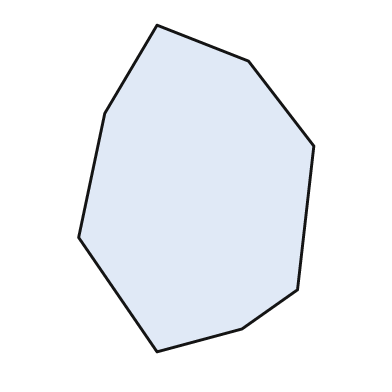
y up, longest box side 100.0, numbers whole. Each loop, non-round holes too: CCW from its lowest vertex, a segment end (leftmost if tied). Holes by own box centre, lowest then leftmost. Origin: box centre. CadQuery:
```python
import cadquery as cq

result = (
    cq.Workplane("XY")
    .moveTo(-12.0, -50.0)
    .lineTo(14.0, -43.0)
    .lineTo(31.0, -31.0)
    .lineTo(36.0, 13.0)
    .lineTo(16.0, 39.0)
    .lineTo(-12.0, 50.0)
    .lineTo(-28.0, 23.0)
    .lineTo(-36.0, -15.0)
    .close()
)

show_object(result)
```